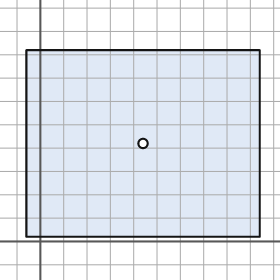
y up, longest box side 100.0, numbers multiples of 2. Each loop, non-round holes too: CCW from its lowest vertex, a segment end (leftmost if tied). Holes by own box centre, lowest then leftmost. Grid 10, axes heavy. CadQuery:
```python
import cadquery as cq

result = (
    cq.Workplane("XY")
    .moveTo(-6.0, 2.0)
    .lineTo(94.0, 2.0)
    .lineTo(94.0, 82.0)
    .lineTo(-6.0, 82.0)
    .close()
    .moveTo(44.0, 42.0)
    .circle(2.0)
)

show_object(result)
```